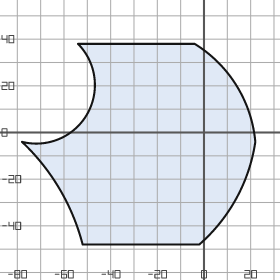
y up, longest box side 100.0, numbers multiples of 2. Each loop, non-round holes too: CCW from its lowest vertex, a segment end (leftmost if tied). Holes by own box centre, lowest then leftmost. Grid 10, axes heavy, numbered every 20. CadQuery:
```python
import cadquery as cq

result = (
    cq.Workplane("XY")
    .moveTo(-52.0, -48.0)
    .lineTo(-2.0, -48.0)
    .threePointArc((14.0, -28.0), (22.0, -4.0))
    .threePointArc((14.0, 20.0), (-4.0, 38.0))
    .lineTo(-54.0, 38.0)
    .threePointArc((-50.0, 8.0), (-78.0, -4.0))
    .threePointArc((-62.0, -24.0), (-52.0, -48.0))
    .close()
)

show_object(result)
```